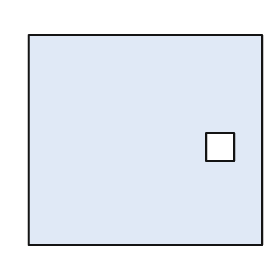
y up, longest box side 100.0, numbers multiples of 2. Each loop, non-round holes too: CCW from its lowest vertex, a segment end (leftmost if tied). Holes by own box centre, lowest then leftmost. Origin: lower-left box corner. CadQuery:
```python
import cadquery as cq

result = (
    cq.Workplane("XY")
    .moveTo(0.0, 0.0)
    .lineTo(100.0, 0.0)
    .lineTo(100.0, 90.0)
    .lineTo(0.0, 90.0)
    .close()
    .moveTo(76.0, 36.0)
    .lineTo(88.0, 36.0)
    .lineTo(88.0, 48.0)
    .lineTo(76.0, 48.0)
    .close()
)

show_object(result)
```